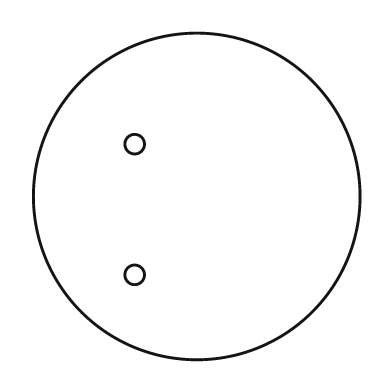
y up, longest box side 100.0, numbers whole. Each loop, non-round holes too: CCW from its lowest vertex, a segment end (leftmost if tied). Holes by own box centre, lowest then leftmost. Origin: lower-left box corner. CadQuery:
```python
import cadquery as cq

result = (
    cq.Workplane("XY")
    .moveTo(50.0, 50.0)
    .circle(50.0)
    .moveTo(31.0, 26.0)
    .circle(3.0)
    .moveTo(31.0, 66.0)
    .circle(3.0)
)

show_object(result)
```